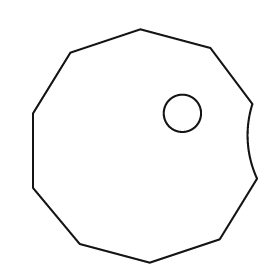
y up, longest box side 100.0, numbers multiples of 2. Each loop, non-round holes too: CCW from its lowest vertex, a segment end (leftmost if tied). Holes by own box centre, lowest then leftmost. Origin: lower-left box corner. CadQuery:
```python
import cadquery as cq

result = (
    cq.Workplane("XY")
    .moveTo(50.0, 0.0)
    .lineTo(80.0, 10.0)
    .lineTo(96.0, 36.0)
    .threePointArc((92.0, 52.0), (94.0, 68.0))
    .lineTo(76.0, 92.0)
    .lineTo(46.0, 100.0)
    .lineTo(16.0, 90.0)
    .lineTo(0.0, 64.0)
    .lineTo(0.0, 32.0)
    .lineTo(20.0, 8.0)
    .close()
    .moveTo(64.0, 64.0)
    .circle(8.0)
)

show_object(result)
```